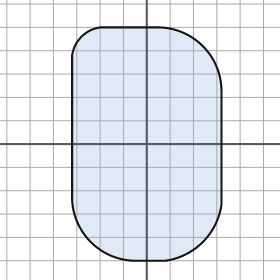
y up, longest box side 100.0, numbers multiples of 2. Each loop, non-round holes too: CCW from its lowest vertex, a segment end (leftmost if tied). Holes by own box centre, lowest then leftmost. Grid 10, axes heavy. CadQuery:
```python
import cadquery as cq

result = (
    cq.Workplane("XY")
    .moveTo(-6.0, -50.0)
    .lineTo(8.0, -50.0)
    .threePointArc((24.0, -42.0), (32.0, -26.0))
    .lineTo(32.0, 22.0)
    .threePointArc((24.0, 42.0), (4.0, 50.0))
    .lineTo(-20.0, 50.0)
    .threePointArc((-28.0, 46.0), (-32.0, 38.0))
    .lineTo(-32.0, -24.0)
    .threePointArc((-24.0, -42.0), (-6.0, -50.0))
    .close()
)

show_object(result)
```